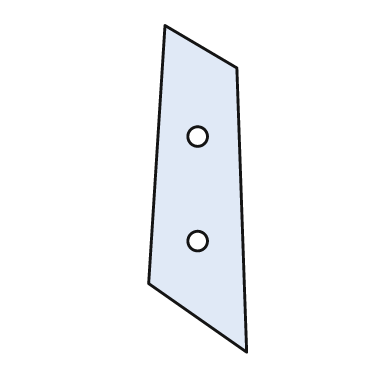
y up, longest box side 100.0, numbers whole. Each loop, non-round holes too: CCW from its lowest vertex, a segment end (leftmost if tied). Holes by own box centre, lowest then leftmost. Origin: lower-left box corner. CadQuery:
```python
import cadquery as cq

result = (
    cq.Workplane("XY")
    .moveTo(30.0, 0.0)
    .lineTo(27.0, 87.0)
    .lineTo(5.0, 100.0)
    .lineTo(0.0, 21.0)
    .close()
    .moveTo(15.0, 34.0)
    .circle(3.0)
    .moveTo(15.0, 66.0)
    .circle(3.0)
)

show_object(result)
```